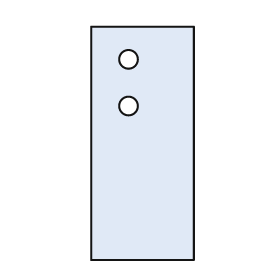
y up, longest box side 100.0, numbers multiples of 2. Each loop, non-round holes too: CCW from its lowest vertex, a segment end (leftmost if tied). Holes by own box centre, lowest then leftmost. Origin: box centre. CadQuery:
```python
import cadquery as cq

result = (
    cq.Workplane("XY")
    .moveTo(-22.0, -50.0)
    .lineTo(22.0, -50.0)
    .lineTo(22.0, 50.0)
    .lineTo(-22.0, 50.0)
    .close()
    .moveTo(-6.0, 16.0)
    .circle(4.0)
    .moveTo(-6.0, 36.0)
    .circle(4.0)
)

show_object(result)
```